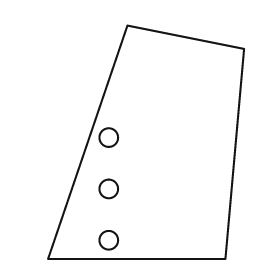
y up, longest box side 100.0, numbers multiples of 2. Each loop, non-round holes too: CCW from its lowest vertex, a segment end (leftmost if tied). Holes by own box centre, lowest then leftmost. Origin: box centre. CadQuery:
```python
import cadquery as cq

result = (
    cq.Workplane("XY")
    .moveTo(-42.0, -50.0)
    .lineTo(34.0, -50.0)
    .lineTo(42.0, 40.0)
    .lineTo(-8.0, 50.0)
    .close()
    .moveTo(-16.0, -42.0)
    .circle(4.0)
    .moveTo(-16.0, -20.0)
    .circle(4.0)
    .moveTo(-16.0, 2.0)
    .circle(4.0)
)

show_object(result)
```